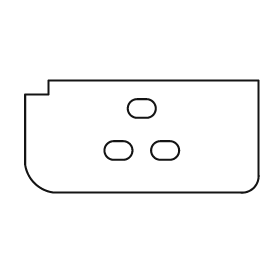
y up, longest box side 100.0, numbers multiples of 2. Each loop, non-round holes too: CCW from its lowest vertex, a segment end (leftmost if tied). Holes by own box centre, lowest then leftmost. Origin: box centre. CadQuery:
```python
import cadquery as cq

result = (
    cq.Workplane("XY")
    .moveTo(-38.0, -24.0)
    .lineTo(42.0, -24.0)
    .threePointArc((48.0, -22.0), (50.0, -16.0))
    .lineTo(50.0, 24.0)
    .lineTo(-40.0, 24.0)
    .lineTo(-40.0, 18.0)
    .lineTo(-50.0, 18.0)
    .lineTo(-50.0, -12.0)
    .threePointArc((-46.0, -20.0), (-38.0, -24.0))
    .close()
    .moveTo(-12.0, -10.0)
    .lineTo(-8.0, -10.0)
    .threePointArc((-4.0, -6.0), (-8.0, -2.0))
    .lineTo(-12.0, -2.0)
    .threePointArc((-16.0, -6.0), (-12.0, -10.0))
    .close()
    .moveTo(8.0, -10.0)
    .lineTo(12.0, -10.0)
    .threePointArc((16.0, -6.0), (12.0, -2.0))
    .lineTo(8.0, -2.0)
    .threePointArc((4.0, -6.0), (8.0, -10.0))
    .close()
    .moveTo(-2.0, 8.0)
    .lineTo(2.0, 8.0)
    .threePointArc((6.0, 12.0), (2.0, 16.0))
    .lineTo(-2.0, 16.0)
    .threePointArc((-6.0, 12.0), (-2.0, 8.0))
    .close()
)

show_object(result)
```